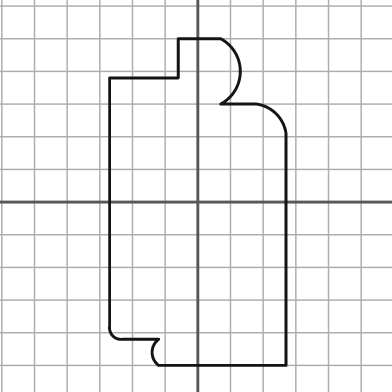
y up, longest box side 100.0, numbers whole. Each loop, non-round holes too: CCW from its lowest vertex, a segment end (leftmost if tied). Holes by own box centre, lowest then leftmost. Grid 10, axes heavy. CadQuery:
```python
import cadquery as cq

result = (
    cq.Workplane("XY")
    .moveTo(-12.0, -50.0)
    .lineTo(27.0, -50.0)
    .lineTo(27.0, 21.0)
    .threePointArc((24.0, 27.0), (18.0, 30.0))
    .lineTo(7.0, 30.0)
    .threePointArc((13.0, 40.0), (7.0, 50.0))
    .lineTo(-6.0, 50.0)
    .lineTo(-6.0, 38.0)
    .lineTo(-27.0, 38.0)
    .lineTo(-27.0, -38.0)
    .threePointArc((-26.0, -41.0), (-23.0, -42.0))
    .lineTo(-12.0, -42.0)
    .threePointArc((-14.0, -46.0), (-12.0, -50.0))
    .close()
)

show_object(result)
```